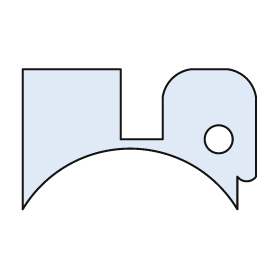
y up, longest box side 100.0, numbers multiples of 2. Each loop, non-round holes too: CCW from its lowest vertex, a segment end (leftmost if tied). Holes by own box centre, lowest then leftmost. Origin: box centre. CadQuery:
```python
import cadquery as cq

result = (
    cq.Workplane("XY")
    .moveTo(-50.0, -30.0)
    .threePointArc((-4.0, -4.0), (42.0, -30.0))
    .lineTo(42.0, -16.0)
    .threePointArc((46.0, -18.0), (50.0, -16.0))
    .lineTo(50.0, 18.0)
    .threePointArc((46.0, 26.0), (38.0, 30.0))
    .lineTo(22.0, 30.0)
    .threePointArc((14.0, 26.0), (10.0, 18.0))
    .lineTo(10.0, 0.0)
    .lineTo(-8.0, 0.0)
    .lineTo(-8.0, 30.0)
    .lineTo(-50.0, 30.0)
    .close()
    .moveTo(34.0, 0.0)
    .circle(6.0)
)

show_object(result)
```